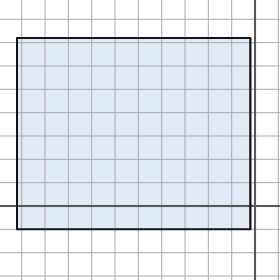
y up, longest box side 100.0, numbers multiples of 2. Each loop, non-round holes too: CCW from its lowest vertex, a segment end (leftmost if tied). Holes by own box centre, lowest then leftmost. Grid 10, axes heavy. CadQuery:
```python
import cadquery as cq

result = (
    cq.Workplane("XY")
    .moveTo(-102.0, -10.0)
    .lineTo(-2.0, -10.0)
    .lineTo(-2.0, 72.0)
    .lineTo(-102.0, 72.0)
    .close()
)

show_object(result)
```